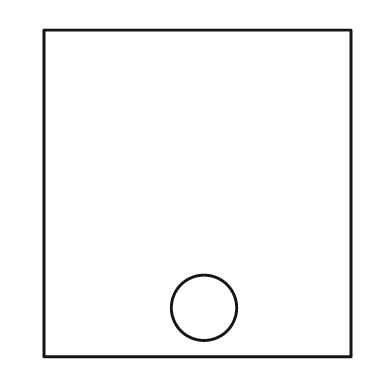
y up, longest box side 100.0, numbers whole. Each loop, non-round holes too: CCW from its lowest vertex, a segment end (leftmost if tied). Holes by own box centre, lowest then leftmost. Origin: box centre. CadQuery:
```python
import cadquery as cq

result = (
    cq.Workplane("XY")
    .moveTo(-47.0, -50.0)
    .lineTo(47.0, -50.0)
    .lineTo(47.0, 50.0)
    .lineTo(-47.0, 50.0)
    .close()
    .moveTo(2.0, -35.0)
    .circle(10.0)
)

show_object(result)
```